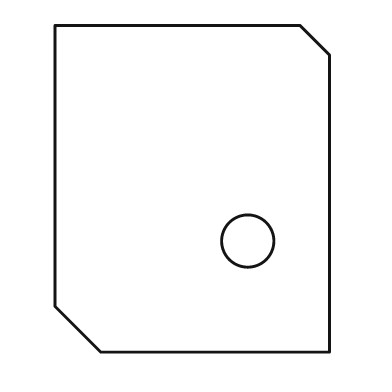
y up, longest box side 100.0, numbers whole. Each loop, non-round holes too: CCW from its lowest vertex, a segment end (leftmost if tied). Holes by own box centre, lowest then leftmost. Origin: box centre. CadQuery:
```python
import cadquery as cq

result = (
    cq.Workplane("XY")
    .moveTo(-28.0, -50.0)
    .lineTo(42.0, -50.0)
    .lineTo(42.0, 41.0)
    .lineTo(33.0, 50.0)
    .lineTo(-42.0, 50.0)
    .lineTo(-42.0, -36.0)
    .close()
    .moveTo(17.0, -16.0)
    .circle(8.0)
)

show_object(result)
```